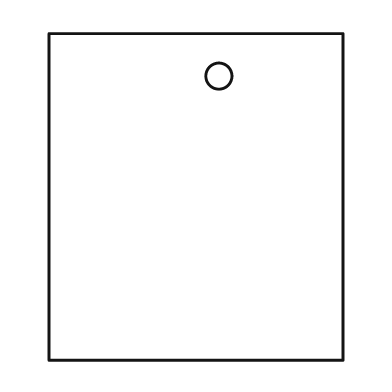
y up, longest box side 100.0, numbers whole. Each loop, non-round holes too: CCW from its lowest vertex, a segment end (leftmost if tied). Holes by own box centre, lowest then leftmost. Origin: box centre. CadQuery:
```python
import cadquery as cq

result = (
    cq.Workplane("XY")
    .moveTo(-45.0, -50.0)
    .lineTo(45.0, -50.0)
    .lineTo(45.0, 50.0)
    .lineTo(-45.0, 50.0)
    .close()
    .moveTo(7.0, 37.0)
    .circle(4.0)
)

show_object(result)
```